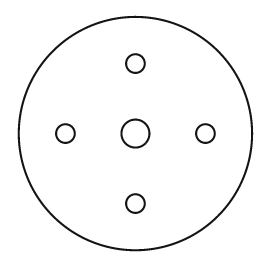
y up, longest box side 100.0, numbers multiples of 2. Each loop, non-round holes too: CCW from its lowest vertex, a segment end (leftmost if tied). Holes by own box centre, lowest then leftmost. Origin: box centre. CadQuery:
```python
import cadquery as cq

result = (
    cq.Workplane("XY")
    .moveTo(0.0, 0.0)
    .circle(50.0)
    .moveTo(0.0, -30.0)
    .circle(4.0)
    .moveTo(-30.0, 0.0)
    .circle(4.0)
    .moveTo(0.0, 0.0)
    .circle(6.0)
    .moveTo(30.0, 0.0)
    .circle(4.0)
    .moveTo(0.0, 30.0)
    .circle(4.0)
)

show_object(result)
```